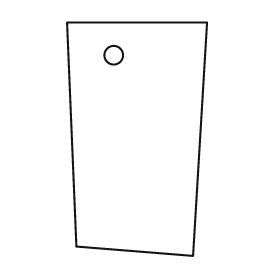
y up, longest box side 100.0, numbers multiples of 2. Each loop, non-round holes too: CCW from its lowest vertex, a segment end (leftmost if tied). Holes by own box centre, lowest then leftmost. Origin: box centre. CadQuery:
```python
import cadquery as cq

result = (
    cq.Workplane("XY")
    .moveTo(24.0, -50.0)
    .lineTo(30.0, 50.0)
    .lineTo(-30.0, 50.0)
    .lineTo(-26.0, -46.0)
    .close()
    .moveTo(-10.0, 36.0)
    .circle(4.0)
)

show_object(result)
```